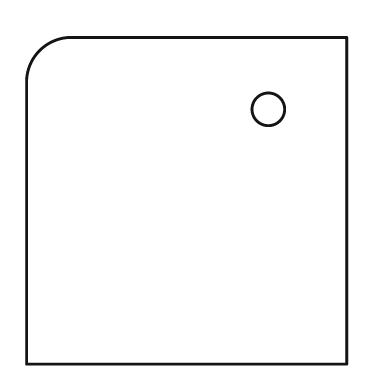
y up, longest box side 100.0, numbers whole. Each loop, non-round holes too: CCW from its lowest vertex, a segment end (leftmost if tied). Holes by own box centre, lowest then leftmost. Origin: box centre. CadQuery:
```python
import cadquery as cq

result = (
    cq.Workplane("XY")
    .moveTo(-49.0, -50.0)
    .lineTo(49.0, -50.0)
    .lineTo(49.0, 50.0)
    .lineTo(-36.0, 50.0)
    .threePointArc((-45.0, 46.0), (-49.0, 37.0))
    .close()
    .moveTo(25.0, 28.0)
    .circle(5.0)
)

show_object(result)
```